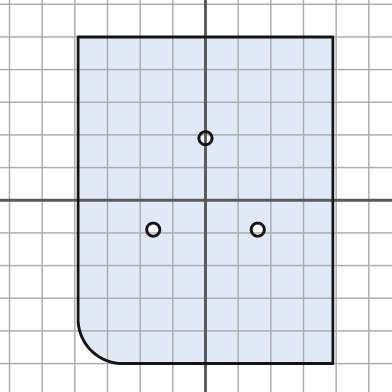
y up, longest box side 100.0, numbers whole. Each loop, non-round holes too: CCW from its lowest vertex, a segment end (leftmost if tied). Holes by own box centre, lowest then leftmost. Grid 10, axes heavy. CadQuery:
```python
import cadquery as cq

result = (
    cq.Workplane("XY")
    .moveTo(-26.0, -50.0)
    .lineTo(39.0, -50.0)
    .lineTo(39.0, 50.0)
    .lineTo(-39.0, 50.0)
    .lineTo(-39.0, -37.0)
    .threePointArc((-35.0, -46.0), (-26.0, -50.0))
    .close()
    .moveTo(-16.0, -9.0)
    .circle(2.0)
    .moveTo(16.0, -9.0)
    .circle(2.0)
    .moveTo(0.0, 19.0)
    .circle(2.0)
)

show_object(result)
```